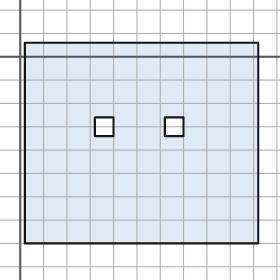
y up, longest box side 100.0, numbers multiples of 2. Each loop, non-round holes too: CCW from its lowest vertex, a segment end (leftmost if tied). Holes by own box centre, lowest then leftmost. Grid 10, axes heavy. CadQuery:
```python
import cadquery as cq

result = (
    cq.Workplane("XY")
    .moveTo(2.0, -80.0)
    .lineTo(102.0, -80.0)
    .lineTo(102.0, 6.0)
    .lineTo(2.0, 6.0)
    .close()
    .moveTo(32.0, -34.0)
    .lineTo(40.0, -34.0)
    .lineTo(40.0, -26.0)
    .lineTo(32.0, -26.0)
    .close()
    .moveTo(62.0, -34.0)
    .lineTo(70.0, -34.0)
    .lineTo(70.0, -26.0)
    .lineTo(62.0, -26.0)
    .close()
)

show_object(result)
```